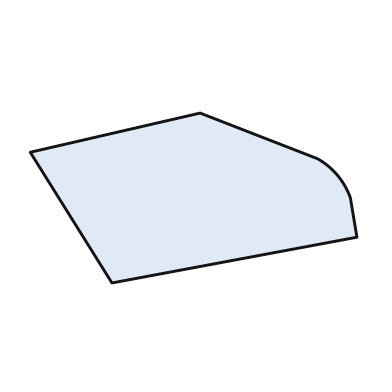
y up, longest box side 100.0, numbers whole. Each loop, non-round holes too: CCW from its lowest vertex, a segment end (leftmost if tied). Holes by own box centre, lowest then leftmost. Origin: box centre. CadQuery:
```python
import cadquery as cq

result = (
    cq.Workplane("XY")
    .moveTo(-25.0, -26.0)
    .lineTo(50.0, -12.0)
    .lineTo(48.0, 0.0)
    .threePointArc((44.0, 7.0), (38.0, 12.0))
    .lineTo(2.0, 26.0)
    .lineTo(-50.0, 14.0)
    .close()
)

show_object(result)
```